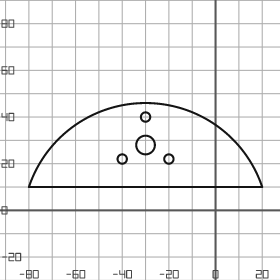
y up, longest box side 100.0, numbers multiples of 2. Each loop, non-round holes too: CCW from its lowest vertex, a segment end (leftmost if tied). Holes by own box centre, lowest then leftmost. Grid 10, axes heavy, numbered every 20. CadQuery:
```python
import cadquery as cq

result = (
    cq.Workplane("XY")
    .moveTo(-80.0, 10.0)
    .lineTo(20.0, 10.0)
    .threePointArc((-30.0, 46.0), (-80.0, 10.0))
    .close()
    .moveTo(-40.0, 22.0)
    .circle(2.0)
    .moveTo(-20.0, 22.0)
    .circle(2.0)
    .moveTo(-30.0, 28.0)
    .circle(4.0)
    .moveTo(-30.0, 40.0)
    .circle(2.0)
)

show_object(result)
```